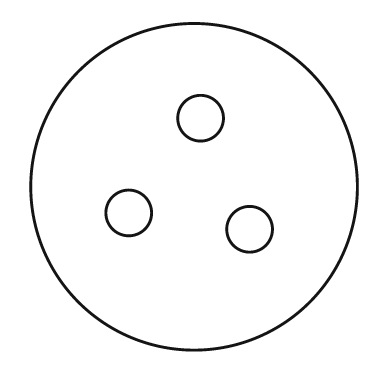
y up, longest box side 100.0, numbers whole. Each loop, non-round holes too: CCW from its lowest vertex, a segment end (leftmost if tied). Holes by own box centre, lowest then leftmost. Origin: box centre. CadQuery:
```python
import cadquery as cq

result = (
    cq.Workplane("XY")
    .moveTo(0.0, 0.0)
    .circle(50.0)
    .moveTo(17.0, -13.0)
    .circle(7.0)
    .moveTo(-20.0, -8.0)
    .circle(7.0)
    .moveTo(2.0, 21.0)
    .circle(7.0)
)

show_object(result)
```